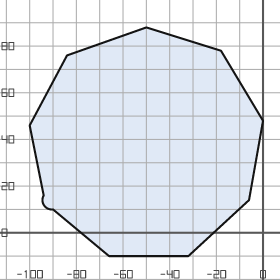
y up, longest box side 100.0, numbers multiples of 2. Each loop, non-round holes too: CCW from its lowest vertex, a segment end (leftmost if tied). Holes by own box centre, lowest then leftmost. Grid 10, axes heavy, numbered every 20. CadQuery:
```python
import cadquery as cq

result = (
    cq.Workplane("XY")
    .moveTo(-66.0, -10.0)
    .lineTo(-32.0, -10.0)
    .lineTo(-6.0, 14.0)
    .lineTo(0.0, 48.0)
    .lineTo(-18.0, 78.0)
    .lineTo(-50.0, 88.0)
    .lineTo(-84.0, 76.0)
    .lineTo(-100.0, 46.0)
    .lineTo(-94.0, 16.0)
    .threePointArc((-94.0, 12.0), (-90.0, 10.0))
    .close()
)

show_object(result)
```